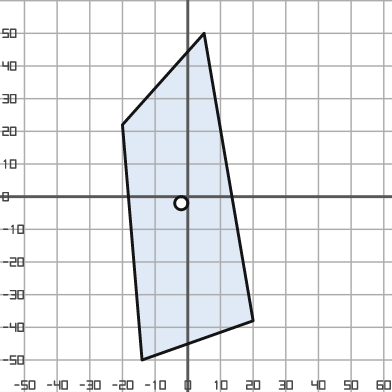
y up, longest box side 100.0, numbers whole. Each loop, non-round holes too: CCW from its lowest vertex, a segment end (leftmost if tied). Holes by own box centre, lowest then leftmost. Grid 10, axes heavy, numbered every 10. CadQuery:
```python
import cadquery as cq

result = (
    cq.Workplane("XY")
    .moveTo(-14.0, -50.0)
    .lineTo(20.0, -38.0)
    .lineTo(5.0, 50.0)
    .lineTo(-20.0, 22.0)
    .close()
    .moveTo(-2.0, -2.0)
    .circle(2.0)
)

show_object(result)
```